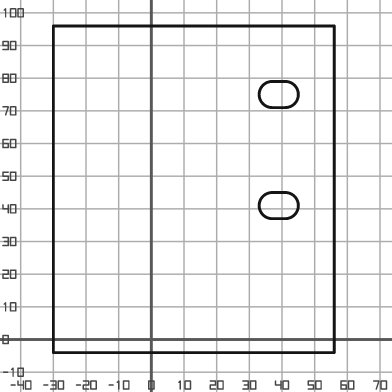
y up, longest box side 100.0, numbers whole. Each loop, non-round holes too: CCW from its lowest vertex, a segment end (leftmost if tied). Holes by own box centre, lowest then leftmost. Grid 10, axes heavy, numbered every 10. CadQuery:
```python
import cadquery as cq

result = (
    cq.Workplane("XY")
    .moveTo(-30.0, -4.0)
    .lineTo(56.0, -4.0)
    .lineTo(56.0, 96.0)
    .lineTo(-30.0, 96.0)
    .close()
    .moveTo(37.0, 37.0)
    .lineTo(41.0, 37.0)
    .threePointArc((45.0, 41.0), (41.0, 45.0))
    .lineTo(37.0, 45.0)
    .threePointArc((33.0, 41.0), (37.0, 37.0))
    .close()
    .moveTo(37.0, 71.0)
    .lineTo(41.0, 71.0)
    .threePointArc((45.0, 75.0), (41.0, 79.0))
    .lineTo(37.0, 79.0)
    .threePointArc((33.0, 75.0), (37.0, 71.0))
    .close()
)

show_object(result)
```